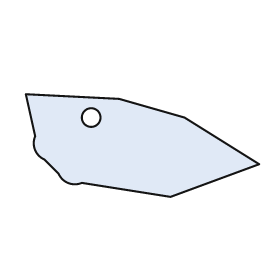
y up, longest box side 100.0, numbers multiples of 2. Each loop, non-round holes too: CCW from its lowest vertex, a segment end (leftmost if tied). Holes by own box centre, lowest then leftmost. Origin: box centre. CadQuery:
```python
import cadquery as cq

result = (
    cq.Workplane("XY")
    .moveTo(12.0, -22.0)
    .lineTo(50.0, -8.0)
    .lineTo(18.0, 12.0)
    .lineTo(-10.0, 20.0)
    .lineTo(-50.0, 22.0)
    .lineTo(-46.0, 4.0)
    .threePointArc((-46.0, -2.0), (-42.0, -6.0))
    .lineTo(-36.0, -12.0)
    .threePointArc((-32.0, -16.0), (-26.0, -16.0))
    .close()
    .moveTo(-22.0, 12.0)
    .circle(4.0)
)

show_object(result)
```